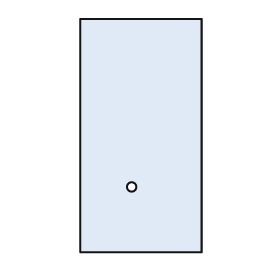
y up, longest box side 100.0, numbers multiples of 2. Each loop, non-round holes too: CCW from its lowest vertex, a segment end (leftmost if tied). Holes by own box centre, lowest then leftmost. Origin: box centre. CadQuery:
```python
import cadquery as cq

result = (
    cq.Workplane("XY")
    .moveTo(-26.0, -50.0)
    .lineTo(26.0, -50.0)
    .lineTo(26.0, 50.0)
    .lineTo(-26.0, 50.0)
    .close()
    .moveTo(-4.0, -22.0)
    .circle(2.0)
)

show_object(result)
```